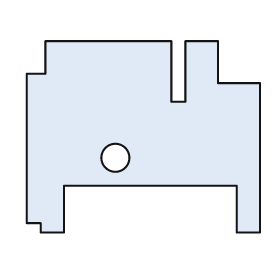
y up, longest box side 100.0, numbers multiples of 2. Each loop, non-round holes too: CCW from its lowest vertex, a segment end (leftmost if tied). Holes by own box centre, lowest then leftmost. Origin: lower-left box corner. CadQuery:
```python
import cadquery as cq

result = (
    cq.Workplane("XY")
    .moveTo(6.0, 0.0)
    .lineTo(16.0, 0.0)
    .lineTo(16.0, 20.0)
    .lineTo(90.0, 20.0)
    .lineTo(90.0, 0.0)
    .lineTo(100.0, 0.0)
    .lineTo(100.0, 64.0)
    .lineTo(82.0, 64.0)
    .lineTo(82.0, 82.0)
    .lineTo(68.0, 82.0)
    .lineTo(68.0, 56.0)
    .lineTo(62.0, 56.0)
    .lineTo(62.0, 82.0)
    .lineTo(8.0, 82.0)
    .lineTo(8.0, 68.0)
    .lineTo(0.0, 68.0)
    .lineTo(0.0, 4.0)
    .lineTo(6.0, 4.0)
    .close()
    .moveTo(38.0, 32.0)
    .circle(6.0)
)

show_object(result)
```